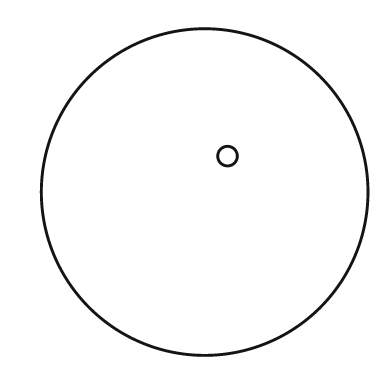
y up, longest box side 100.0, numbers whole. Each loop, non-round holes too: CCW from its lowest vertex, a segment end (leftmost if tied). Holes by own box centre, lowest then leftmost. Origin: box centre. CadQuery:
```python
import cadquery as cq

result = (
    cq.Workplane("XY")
    .moveTo(0.0, 0.0)
    .circle(50.0)
    .moveTo(7.0, 11.0)
    .circle(3.0)
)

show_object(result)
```